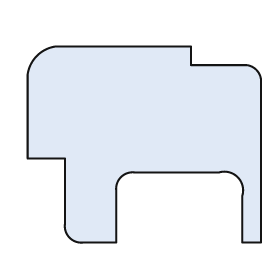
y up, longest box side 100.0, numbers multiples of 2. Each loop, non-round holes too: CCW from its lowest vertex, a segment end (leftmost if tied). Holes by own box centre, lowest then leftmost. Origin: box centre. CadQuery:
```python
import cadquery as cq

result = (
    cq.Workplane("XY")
    .moveTo(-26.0, -42.0)
    .lineTo(-12.0, -42.0)
    .lineTo(-12.0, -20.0)
    .threePointArc((-10.0, -14.0), (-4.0, -12.0))
    .lineTo(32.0, -12.0)
    .threePointArc((40.0, -14.0), (42.0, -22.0))
    .lineTo(42.0, -42.0)
    .lineTo(50.0, -42.0)
    .lineTo(50.0, 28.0)
    .threePointArc((48.0, 32.0), (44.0, 34.0))
    .lineTo(20.0, 34.0)
    .lineTo(20.0, 42.0)
    .lineTo(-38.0, 42.0)
    .threePointArc((-46.0, 38.0), (-50.0, 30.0))
    .lineTo(-50.0, -6.0)
    .lineTo(-34.0, -6.0)
    .lineTo(-34.0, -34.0)
    .threePointArc((-32.0, -40.0), (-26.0, -42.0))
    .close()
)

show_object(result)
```